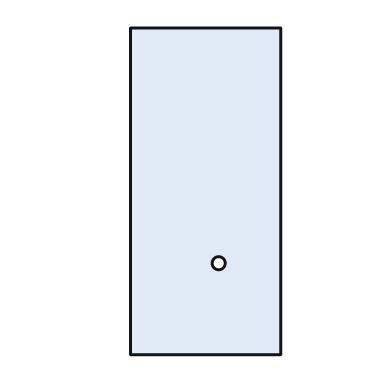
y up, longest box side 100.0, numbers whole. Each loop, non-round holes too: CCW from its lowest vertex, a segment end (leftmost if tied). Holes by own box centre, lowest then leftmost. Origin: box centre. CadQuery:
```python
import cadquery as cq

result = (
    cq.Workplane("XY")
    .moveTo(-23.0, -50.0)
    .lineTo(23.0, -50.0)
    .lineTo(23.0, 50.0)
    .lineTo(-23.0, 50.0)
    .close()
    .moveTo(4.0, -22.0)
    .circle(2.0)
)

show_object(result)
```